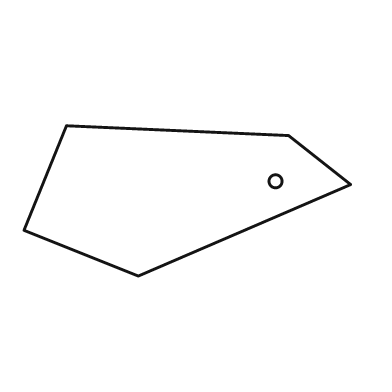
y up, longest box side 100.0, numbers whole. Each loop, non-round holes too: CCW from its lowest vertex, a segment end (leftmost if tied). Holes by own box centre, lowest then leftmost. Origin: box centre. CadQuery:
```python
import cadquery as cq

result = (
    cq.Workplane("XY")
    .moveTo(-15.0, -23.0)
    .lineTo(50.0, 5.0)
    .lineTo(31.0, 20.0)
    .lineTo(-37.0, 23.0)
    .lineTo(-50.0, -9.0)
    .close()
    .moveTo(27.0, 6.0)
    .circle(2.0)
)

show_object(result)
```